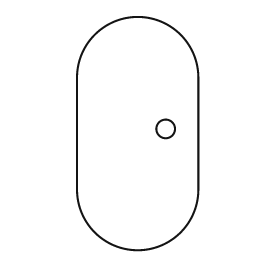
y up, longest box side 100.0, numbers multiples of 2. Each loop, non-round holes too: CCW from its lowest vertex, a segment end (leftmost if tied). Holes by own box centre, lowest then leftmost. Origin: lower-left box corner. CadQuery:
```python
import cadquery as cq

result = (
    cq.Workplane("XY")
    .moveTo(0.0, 26.0)
    .threePointArc((26.0, 0.0), (52.0, 26.0))
    .lineTo(52.0, 74.0)
    .threePointArc((26.0, 100.0), (0.0, 74.0))
    .close()
    .moveTo(38.0, 52.0)
    .circle(4.0)
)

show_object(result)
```